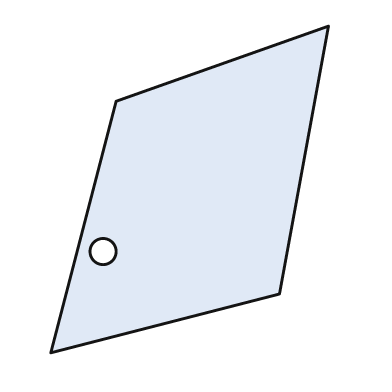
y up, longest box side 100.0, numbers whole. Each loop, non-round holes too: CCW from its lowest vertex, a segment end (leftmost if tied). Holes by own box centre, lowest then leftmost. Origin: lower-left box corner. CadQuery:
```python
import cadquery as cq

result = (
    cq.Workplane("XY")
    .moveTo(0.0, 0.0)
    .lineTo(70.0, 18.0)
    .lineTo(85.0, 100.0)
    .lineTo(20.0, 77.0)
    .close()
    .moveTo(16.0, 31.0)
    .circle(4.0)
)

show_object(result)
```